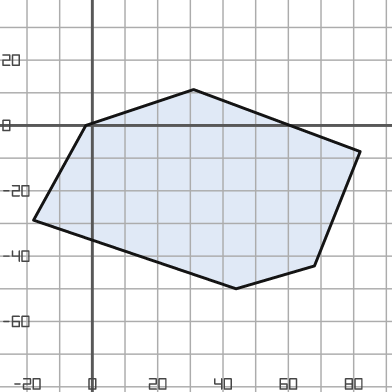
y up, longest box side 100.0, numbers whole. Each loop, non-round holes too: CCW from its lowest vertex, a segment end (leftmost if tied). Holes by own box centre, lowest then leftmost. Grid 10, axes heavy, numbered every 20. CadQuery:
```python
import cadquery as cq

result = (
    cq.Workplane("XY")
    .moveTo(44.0, -50.0)
    .lineTo(68.0, -43.0)
    .lineTo(82.0, -8.0)
    .lineTo(31.0, 11.0)
    .lineTo(-2.0, 0.0)
    .lineTo(-18.0, -29.0)
    .close()
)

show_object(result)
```